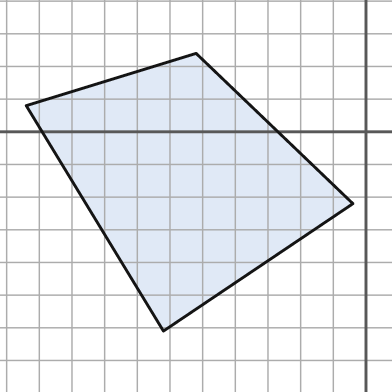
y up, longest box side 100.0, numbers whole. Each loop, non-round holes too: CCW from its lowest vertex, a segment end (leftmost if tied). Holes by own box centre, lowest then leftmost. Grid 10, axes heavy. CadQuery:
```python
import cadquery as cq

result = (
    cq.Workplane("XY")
    .moveTo(-62.0, -61.0)
    .lineTo(-4.0, -22.0)
    .lineTo(-52.0, 24.0)
    .lineTo(-104.0, 8.0)
    .close()
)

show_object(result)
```